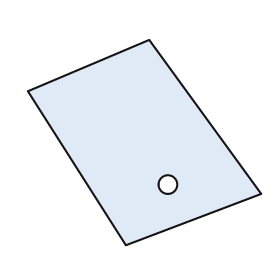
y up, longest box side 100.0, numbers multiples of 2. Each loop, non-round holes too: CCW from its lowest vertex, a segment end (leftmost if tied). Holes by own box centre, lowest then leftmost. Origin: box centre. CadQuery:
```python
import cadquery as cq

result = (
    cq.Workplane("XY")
    .moveTo(-8.0, -44.0)
    .lineTo(50.0, -22.0)
    .lineTo(2.0, 44.0)
    .lineTo(-50.0, 22.0)
    .close()
    .moveTo(10.0, -18.0)
    .circle(4.0)
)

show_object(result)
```